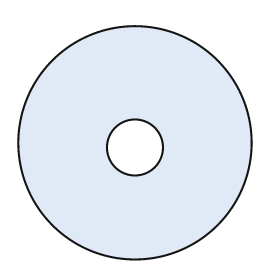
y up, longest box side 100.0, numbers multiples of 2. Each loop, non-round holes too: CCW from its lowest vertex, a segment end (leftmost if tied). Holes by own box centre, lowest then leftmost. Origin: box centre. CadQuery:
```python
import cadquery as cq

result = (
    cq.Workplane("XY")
    .moveTo(0.0, 0.0)
    .circle(50.0)
    .moveTo(0.0, -2.0)
    .circle(12.0)
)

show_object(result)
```